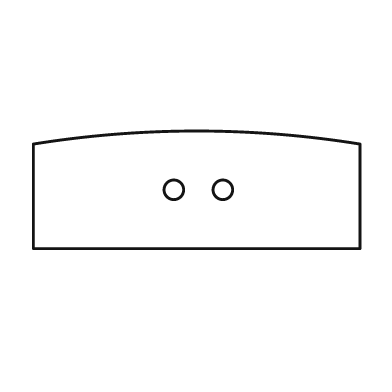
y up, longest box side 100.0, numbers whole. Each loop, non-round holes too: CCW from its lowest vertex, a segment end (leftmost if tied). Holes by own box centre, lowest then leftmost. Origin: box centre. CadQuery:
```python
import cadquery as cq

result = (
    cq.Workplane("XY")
    .moveTo(-50.0, -18.0)
    .lineTo(50.0, -18.0)
    .lineTo(50.0, 14.0)
    .threePointArc((0.0, 18.0), (-50.0, 14.0))
    .close()
    .moveTo(-7.0, 0.0)
    .circle(3.0)
    .moveTo(8.0, 0.0)
    .circle(3.0)
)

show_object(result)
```